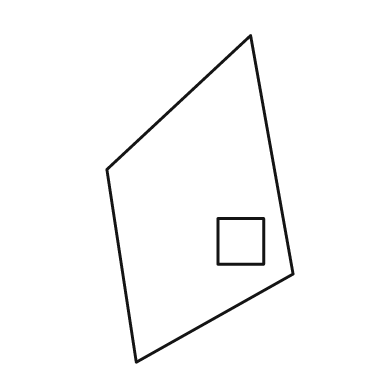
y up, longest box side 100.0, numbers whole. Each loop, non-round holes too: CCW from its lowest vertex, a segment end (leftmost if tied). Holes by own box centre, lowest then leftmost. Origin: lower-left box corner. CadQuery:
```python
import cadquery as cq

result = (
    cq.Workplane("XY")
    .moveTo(9.0, 0.0)
    .lineTo(57.0, 27.0)
    .lineTo(44.0, 100.0)
    .lineTo(0.0, 59.0)
    .close()
    .moveTo(34.0, 30.0)
    .lineTo(48.0, 30.0)
    .lineTo(48.0, 44.0)
    .lineTo(34.0, 44.0)
    .close()
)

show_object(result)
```